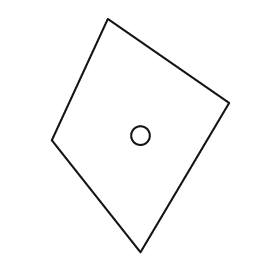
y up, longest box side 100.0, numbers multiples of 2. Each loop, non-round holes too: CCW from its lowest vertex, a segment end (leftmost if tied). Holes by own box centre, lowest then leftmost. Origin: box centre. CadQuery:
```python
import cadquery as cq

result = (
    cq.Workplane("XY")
    .moveTo(0.0, -50.0)
    .lineTo(38.0, 14.0)
    .lineTo(-14.0, 50.0)
    .lineTo(-38.0, -2.0)
    .close()
    .moveTo(0.0, 0.0)
    .circle(4.0)
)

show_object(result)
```